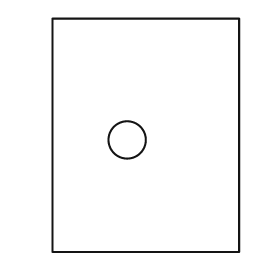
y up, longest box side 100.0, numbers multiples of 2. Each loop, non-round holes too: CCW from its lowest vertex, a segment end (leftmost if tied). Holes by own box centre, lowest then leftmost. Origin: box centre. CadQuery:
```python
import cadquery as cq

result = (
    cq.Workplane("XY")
    .moveTo(-40.0, -50.0)
    .lineTo(40.0, -50.0)
    .lineTo(40.0, 50.0)
    .lineTo(-40.0, 50.0)
    .close()
    .moveTo(-8.0, -2.0)
    .circle(8.0)
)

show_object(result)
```